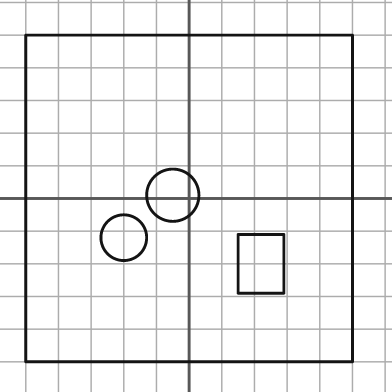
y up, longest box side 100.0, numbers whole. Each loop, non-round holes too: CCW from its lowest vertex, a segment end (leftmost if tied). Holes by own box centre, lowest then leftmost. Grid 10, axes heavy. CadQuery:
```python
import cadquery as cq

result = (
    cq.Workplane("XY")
    .moveTo(-50.0, -50.0)
    .lineTo(50.0, -50.0)
    .lineTo(50.0, 50.0)
    .lineTo(-50.0, 50.0)
    .close()
    .moveTo(15.0, -29.0)
    .lineTo(29.0, -29.0)
    .lineTo(29.0, -11.0)
    .lineTo(15.0, -11.0)
    .close()
    .moveTo(-20.0, -12.0)
    .circle(7.0)
    .moveTo(-5.0, 1.0)
    .circle(8.0)
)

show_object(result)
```